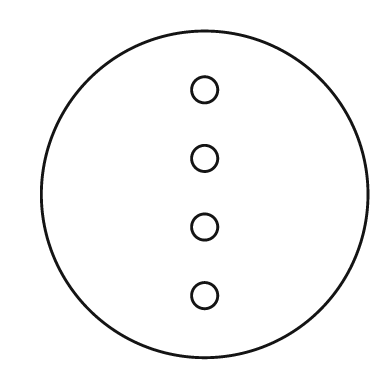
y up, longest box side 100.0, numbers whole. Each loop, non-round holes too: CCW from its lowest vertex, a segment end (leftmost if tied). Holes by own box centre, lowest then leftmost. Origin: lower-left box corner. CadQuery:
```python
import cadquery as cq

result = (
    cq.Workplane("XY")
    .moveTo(50.0, 50.0)
    .circle(50.0)
    .moveTo(50.0, 19.0)
    .circle(4.0)
    .moveTo(50.0, 40.0)
    .circle(4.0)
    .moveTo(50.0, 61.0)
    .circle(4.0)
    .moveTo(50.0, 82.0)
    .circle(4.0)
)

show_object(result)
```